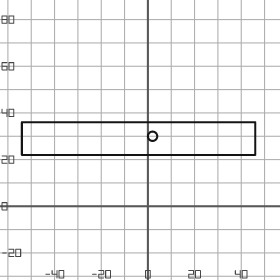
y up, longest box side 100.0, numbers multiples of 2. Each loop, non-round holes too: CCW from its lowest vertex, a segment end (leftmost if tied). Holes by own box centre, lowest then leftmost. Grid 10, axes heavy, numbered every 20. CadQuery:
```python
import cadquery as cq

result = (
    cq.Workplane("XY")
    .moveTo(-54.0, 22.0)
    .lineTo(46.0, 22.0)
    .lineTo(46.0, 36.0)
    .lineTo(-54.0, 36.0)
    .close()
    .moveTo(2.0, 30.0)
    .circle(2.0)
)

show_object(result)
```